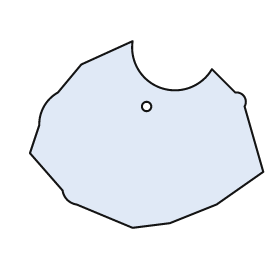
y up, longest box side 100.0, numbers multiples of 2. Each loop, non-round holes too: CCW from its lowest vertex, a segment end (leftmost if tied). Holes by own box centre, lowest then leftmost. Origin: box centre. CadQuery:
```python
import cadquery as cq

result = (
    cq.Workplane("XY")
    .moveTo(-6.0, -40.0)
    .lineTo(10.0, -38.0)
    .lineTo(30.0, -30.0)
    .lineTo(50.0, -16.0)
    .lineTo(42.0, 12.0)
    .threePointArc((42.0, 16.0), (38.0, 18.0))
    .lineTo(28.0, 28.0)
    .threePointArc((6.0, 20.0), (-6.0, 40.0))
    .lineTo(-28.0, 30.0)
    .lineTo(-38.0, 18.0)
    .threePointArc((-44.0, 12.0), (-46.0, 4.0))
    .lineTo(-50.0, -8.0)
    .lineTo(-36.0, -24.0)
    .threePointArc((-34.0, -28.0), (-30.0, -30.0))
    .close()
    .moveTo(0.0, 12.0)
    .circle(2.0)
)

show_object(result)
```